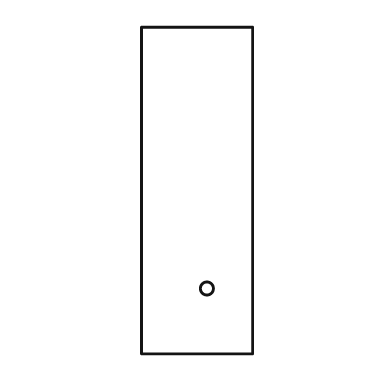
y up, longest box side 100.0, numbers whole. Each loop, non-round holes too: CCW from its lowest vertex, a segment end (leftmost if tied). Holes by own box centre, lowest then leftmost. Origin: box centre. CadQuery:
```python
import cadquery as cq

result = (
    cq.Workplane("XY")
    .moveTo(-17.0, -50.0)
    .lineTo(17.0, -50.0)
    .lineTo(17.0, 50.0)
    .lineTo(-17.0, 50.0)
    .close()
    .moveTo(3.0, -30.0)
    .circle(2.0)
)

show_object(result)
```